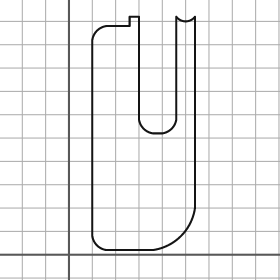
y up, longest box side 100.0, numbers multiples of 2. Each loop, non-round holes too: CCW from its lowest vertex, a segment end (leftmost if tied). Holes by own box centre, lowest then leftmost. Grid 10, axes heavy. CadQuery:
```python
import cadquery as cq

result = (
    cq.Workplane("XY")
    .moveTo(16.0, 2.0)
    .lineTo(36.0, 2.0)
    .threePointArc((48.0, 8.0), (54.0, 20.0))
    .lineTo(54.0, 102.0)
    .threePointArc((50.0, 100.0), (46.0, 102.0))
    .lineTo(46.0, 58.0)
    .threePointArc((44.0, 54.0), (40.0, 52.0))
    .lineTo(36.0, 52.0)
    .threePointArc((32.0, 54.0), (30.0, 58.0))
    .lineTo(30.0, 102.0)
    .lineTo(26.0, 102.0)
    .lineTo(26.0, 98.0)
    .lineTo(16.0, 98.0)
    .threePointArc((12.0, 96.0), (10.0, 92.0))
    .lineTo(10.0, 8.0)
    .threePointArc((12.0, 4.0), (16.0, 2.0))
    .close()
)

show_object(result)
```